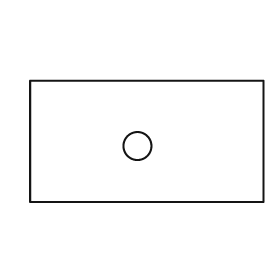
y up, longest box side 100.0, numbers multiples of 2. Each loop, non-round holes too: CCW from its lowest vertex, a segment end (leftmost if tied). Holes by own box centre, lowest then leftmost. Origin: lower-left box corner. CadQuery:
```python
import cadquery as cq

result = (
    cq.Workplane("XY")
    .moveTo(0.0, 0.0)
    .lineTo(100.0, 0.0)
    .lineTo(100.0, 52.0)
    .lineTo(0.0, 52.0)
    .close()
    .moveTo(46.0, 24.0)
    .circle(6.0)
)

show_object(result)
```